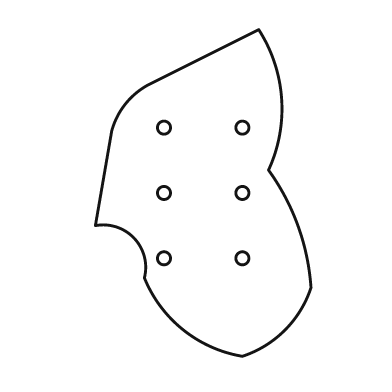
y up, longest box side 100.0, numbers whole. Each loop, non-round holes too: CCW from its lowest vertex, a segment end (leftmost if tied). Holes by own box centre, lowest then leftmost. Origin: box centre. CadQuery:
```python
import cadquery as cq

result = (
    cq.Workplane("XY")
    .moveTo(12.0, -50.0)
    .threePointArc((25.0, -42.0), (33.0, -29.0))
    .threePointArc((29.0, -10.0), (20.0, 7.0))
    .threePointArc((24.0, 29.0), (17.0, 50.0))
    .lineTo(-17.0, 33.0)
    .threePointArc((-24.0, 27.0), (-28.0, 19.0))
    .lineTo(-33.0, -10.0)
    .threePointArc((-21.0, -14.0), (-18.0, -26.0))
    .threePointArc((-6.0, -42.0), (12.0, -50.0))
    .close()
    .moveTo(-12.0, -20.0)
    .circle(2.0)
    .moveTo(12.0, -20.0)
    .circle(2.0)
    .moveTo(-12.0, 0.0)
    .circle(2.0)
    .moveTo(12.0, 0.0)
    .circle(2.0)
    .moveTo(-12.0, 20.0)
    .circle(2.0)
    .moveTo(12.0, 20.0)
    .circle(2.0)
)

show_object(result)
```